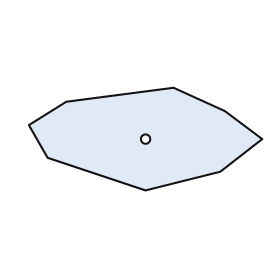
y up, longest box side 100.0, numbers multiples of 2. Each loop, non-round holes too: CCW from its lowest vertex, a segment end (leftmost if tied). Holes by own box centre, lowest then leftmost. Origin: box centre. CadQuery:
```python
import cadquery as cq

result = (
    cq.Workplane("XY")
    .moveTo(0.0, -22.0)
    .lineTo(32.0, -14.0)
    .lineTo(50.0, 0.0)
    .lineTo(34.0, 12.0)
    .lineTo(12.0, 22.0)
    .lineTo(-34.0, 16.0)
    .lineTo(-50.0, 6.0)
    .lineTo(-42.0, -8.0)
    .close()
    .moveTo(0.0, 0.0)
    .circle(2.0)
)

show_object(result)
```